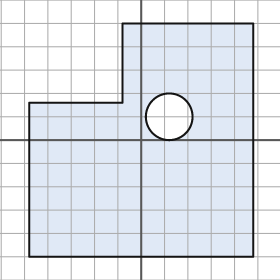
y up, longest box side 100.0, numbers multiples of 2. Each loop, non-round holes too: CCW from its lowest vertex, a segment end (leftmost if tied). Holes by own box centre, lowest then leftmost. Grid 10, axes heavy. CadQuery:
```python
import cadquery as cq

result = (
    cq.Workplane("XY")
    .moveTo(-48.0, -50.0)
    .lineTo(48.0, -50.0)
    .lineTo(48.0, 50.0)
    .lineTo(-8.0, 50.0)
    .lineTo(-8.0, 16.0)
    .lineTo(-48.0, 16.0)
    .close()
    .moveTo(12.0, 10.0)
    .circle(10.0)
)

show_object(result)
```